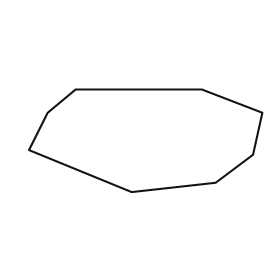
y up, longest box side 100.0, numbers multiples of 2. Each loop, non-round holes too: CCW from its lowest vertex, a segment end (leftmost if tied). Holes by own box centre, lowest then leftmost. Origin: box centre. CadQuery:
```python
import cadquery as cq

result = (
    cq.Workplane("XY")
    .moveTo(-6.0, -22.0)
    .lineTo(30.0, -18.0)
    .lineTo(46.0, -6.0)
    .lineTo(50.0, 12.0)
    .lineTo(24.0, 22.0)
    .lineTo(-30.0, 22.0)
    .lineTo(-42.0, 12.0)
    .lineTo(-50.0, -4.0)
    .close()
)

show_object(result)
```